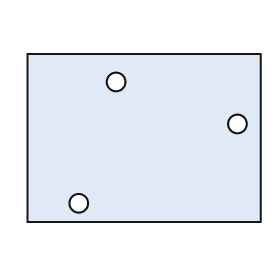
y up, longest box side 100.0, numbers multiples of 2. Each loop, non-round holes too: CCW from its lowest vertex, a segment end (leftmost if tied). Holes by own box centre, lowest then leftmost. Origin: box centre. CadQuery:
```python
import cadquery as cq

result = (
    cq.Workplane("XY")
    .moveTo(-50.0, -36.0)
    .lineTo(50.0, -36.0)
    .lineTo(50.0, 36.0)
    .lineTo(-50.0, 36.0)
    .close()
    .moveTo(-28.0, -28.0)
    .circle(4.0)
    .moveTo(40.0, 6.0)
    .circle(4.0)
    .moveTo(-12.0, 24.0)
    .circle(4.0)
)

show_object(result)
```